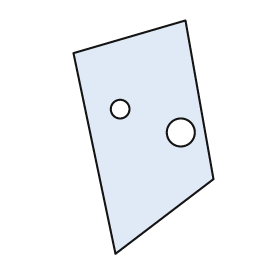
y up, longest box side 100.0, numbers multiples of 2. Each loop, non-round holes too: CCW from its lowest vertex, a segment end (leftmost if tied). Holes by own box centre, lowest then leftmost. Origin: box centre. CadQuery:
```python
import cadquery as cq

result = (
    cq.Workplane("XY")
    .moveTo(-12.0, -50.0)
    .lineTo(30.0, -18.0)
    .lineTo(18.0, 50.0)
    .lineTo(-30.0, 36.0)
    .close()
    .moveTo(16.0, 2.0)
    .circle(6.0)
    .moveTo(-10.0, 12.0)
    .circle(4.0)
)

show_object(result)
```